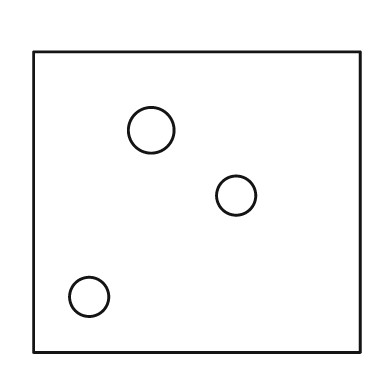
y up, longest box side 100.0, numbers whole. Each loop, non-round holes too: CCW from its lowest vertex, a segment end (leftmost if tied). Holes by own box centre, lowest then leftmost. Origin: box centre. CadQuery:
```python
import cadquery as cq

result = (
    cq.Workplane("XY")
    .moveTo(-50.0, -46.0)
    .lineTo(50.0, -46.0)
    .lineTo(50.0, 46.0)
    .lineTo(-50.0, 46.0)
    .close()
    .moveTo(-33.0, -29.0)
    .circle(6.0)
    .moveTo(12.0, 2.0)
    .circle(6.0)
    .moveTo(-14.0, 22.0)
    .circle(7.0)
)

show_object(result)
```